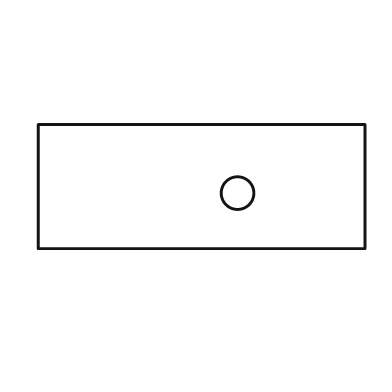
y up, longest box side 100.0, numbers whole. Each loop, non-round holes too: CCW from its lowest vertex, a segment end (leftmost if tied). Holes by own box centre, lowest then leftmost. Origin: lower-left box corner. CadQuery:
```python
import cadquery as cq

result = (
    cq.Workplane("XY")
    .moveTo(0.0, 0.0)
    .lineTo(100.0, 0.0)
    .lineTo(100.0, 38.0)
    .lineTo(0.0, 38.0)
    .close()
    .moveTo(61.0, 17.0)
    .circle(5.0)
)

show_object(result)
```